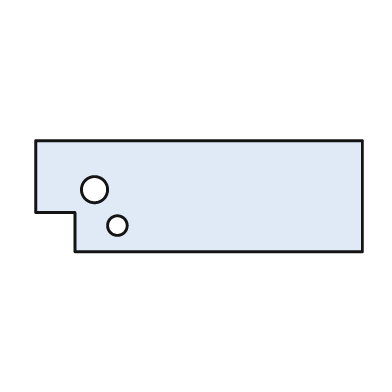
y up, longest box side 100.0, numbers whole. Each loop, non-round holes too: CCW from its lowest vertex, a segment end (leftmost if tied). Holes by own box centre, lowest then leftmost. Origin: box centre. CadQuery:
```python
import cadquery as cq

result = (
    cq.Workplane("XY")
    .moveTo(-38.0, -17.0)
    .lineTo(50.0, -17.0)
    .lineTo(50.0, 17.0)
    .lineTo(-50.0, 17.0)
    .lineTo(-50.0, -5.0)
    .lineTo(-38.0, -5.0)
    .close()
    .moveTo(-25.0, -9.0)
    .circle(3.0)
    .moveTo(-32.0, 2.0)
    .circle(4.0)
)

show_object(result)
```